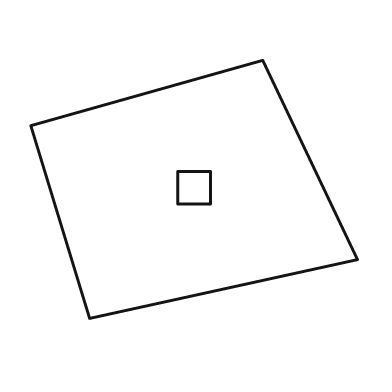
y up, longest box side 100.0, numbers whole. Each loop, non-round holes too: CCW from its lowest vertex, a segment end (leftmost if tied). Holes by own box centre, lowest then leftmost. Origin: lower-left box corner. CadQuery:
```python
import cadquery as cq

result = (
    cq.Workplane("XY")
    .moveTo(18.0, 0.0)
    .lineTo(100.0, 18.0)
    .lineTo(71.0, 79.0)
    .lineTo(0.0, 59.0)
    .close()
    .moveTo(45.0, 35.0)
    .lineTo(55.0, 35.0)
    .lineTo(55.0, 45.0)
    .lineTo(45.0, 45.0)
    .close()
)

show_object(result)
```